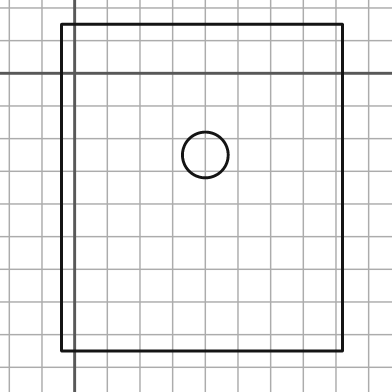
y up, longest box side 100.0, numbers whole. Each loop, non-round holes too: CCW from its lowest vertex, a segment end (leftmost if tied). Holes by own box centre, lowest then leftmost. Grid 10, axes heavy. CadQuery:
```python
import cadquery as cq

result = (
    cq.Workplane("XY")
    .moveTo(-4.0, -85.0)
    .lineTo(82.0, -85.0)
    .lineTo(82.0, 15.0)
    .lineTo(-4.0, 15.0)
    .close()
    .moveTo(40.0, -25.0)
    .circle(7.0)
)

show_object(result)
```